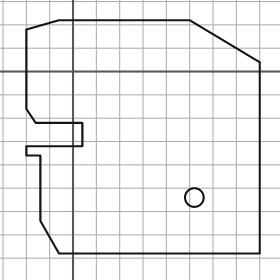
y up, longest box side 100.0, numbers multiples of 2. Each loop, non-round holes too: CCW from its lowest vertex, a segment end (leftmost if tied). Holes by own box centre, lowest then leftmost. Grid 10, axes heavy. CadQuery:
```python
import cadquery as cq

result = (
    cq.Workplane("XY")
    .moveTo(-6.0, -78.0)
    .lineTo(80.0, -78.0)
    .lineTo(80.0, 4.0)
    .lineTo(50.0, 22.0)
    .lineTo(-6.0, 22.0)
    .lineTo(-20.0, 18.0)
    .lineTo(-20.0, -16.0)
    .lineTo(-16.0, -22.0)
    .lineTo(4.0, -22.0)
    .lineTo(4.0, -32.0)
    .lineTo(-20.0, -32.0)
    .lineTo(-20.0, -36.0)
    .lineTo(-14.0, -36.0)
    .lineTo(-14.0, -64.0)
    .close()
    .moveTo(52.0, -54.0)
    .circle(4.0)
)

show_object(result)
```